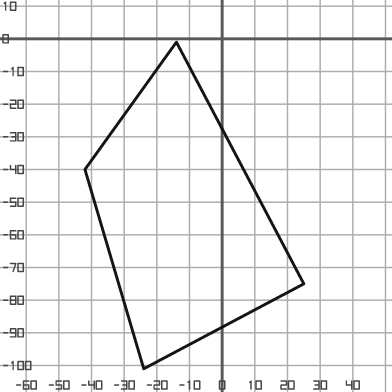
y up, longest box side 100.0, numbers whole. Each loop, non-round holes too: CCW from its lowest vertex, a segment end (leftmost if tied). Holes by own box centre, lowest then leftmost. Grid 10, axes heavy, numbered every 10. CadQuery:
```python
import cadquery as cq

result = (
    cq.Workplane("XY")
    .moveTo(-24.0, -101.0)
    .lineTo(25.0, -75.0)
    .lineTo(-14.0, -1.0)
    .lineTo(-42.0, -40.0)
    .close()
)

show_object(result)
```